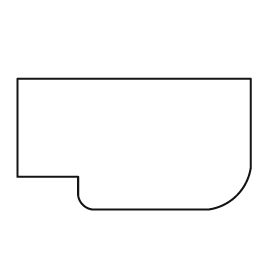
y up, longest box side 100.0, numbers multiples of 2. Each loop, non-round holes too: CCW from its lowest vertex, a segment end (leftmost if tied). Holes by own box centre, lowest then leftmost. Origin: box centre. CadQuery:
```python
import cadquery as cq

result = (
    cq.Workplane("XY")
    .moveTo(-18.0, -28.0)
    .lineTo(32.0, -28.0)
    .threePointArc((44.0, -22.0), (50.0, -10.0))
    .lineTo(50.0, 28.0)
    .lineTo(-50.0, 28.0)
    .lineTo(-50.0, -14.0)
    .lineTo(-24.0, -14.0)
    .lineTo(-24.0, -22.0)
    .threePointArc((-22.0, -26.0), (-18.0, -28.0))
    .close()
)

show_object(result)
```